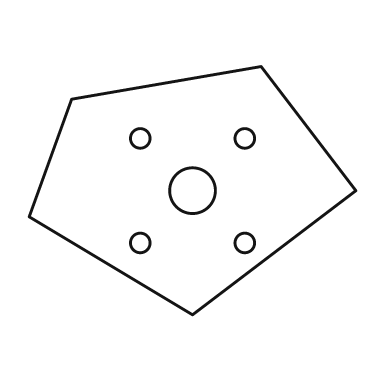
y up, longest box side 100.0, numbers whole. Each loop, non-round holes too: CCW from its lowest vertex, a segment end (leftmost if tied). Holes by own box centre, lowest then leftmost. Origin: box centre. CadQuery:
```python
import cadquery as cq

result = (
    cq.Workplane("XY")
    .moveTo(0.0, -38.0)
    .lineTo(50.0, 0.0)
    .lineTo(21.0, 38.0)
    .lineTo(-37.0, 28.0)
    .lineTo(-50.0, -8.0)
    .close()
    .moveTo(-16.0, -16.0)
    .circle(3.0)
    .moveTo(16.0, -16.0)
    .circle(3.0)
    .moveTo(0.0, 0.0)
    .circle(7.0)
    .moveTo(-16.0, 16.0)
    .circle(3.0)
    .moveTo(16.0, 16.0)
    .circle(3.0)
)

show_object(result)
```